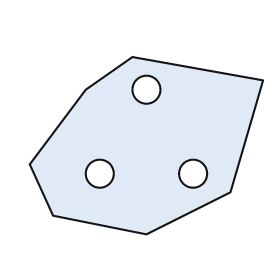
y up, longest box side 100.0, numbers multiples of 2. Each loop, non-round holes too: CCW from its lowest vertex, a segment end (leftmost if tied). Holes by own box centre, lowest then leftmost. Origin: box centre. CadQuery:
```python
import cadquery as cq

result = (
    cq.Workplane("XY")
    .moveTo(0.0, -38.0)
    .lineTo(36.0, -20.0)
    .lineTo(50.0, 28.0)
    .lineTo(-6.0, 38.0)
    .lineTo(-26.0, 24.0)
    .lineTo(-50.0, -8.0)
    .lineTo(-40.0, -30.0)
    .close()
    .moveTo(-20.0, -12.0)
    .circle(6.0)
    .moveTo(20.0, -12.0)
    .circle(6.0)
    .moveTo(0.0, 24.0)
    .circle(6.0)
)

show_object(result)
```